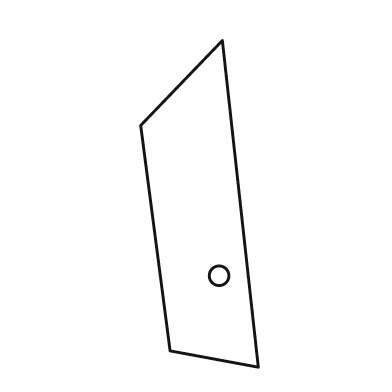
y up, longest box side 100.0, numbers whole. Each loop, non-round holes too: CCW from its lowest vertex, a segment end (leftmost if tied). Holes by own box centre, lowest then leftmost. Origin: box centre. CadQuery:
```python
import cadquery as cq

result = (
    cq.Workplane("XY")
    .moveTo(18.0, -50.0)
    .lineTo(7.0, 50.0)
    .lineTo(-18.0, 24.0)
    .lineTo(-9.0, -45.0)
    .close()
    .moveTo(6.0, -22.0)
    .circle(3.0)
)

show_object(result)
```